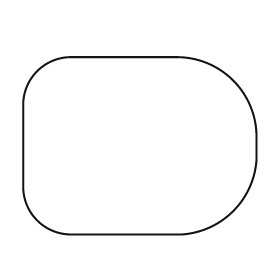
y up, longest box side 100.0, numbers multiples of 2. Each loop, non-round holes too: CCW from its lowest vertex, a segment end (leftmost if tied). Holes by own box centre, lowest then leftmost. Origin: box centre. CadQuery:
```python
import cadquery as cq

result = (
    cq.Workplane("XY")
    .moveTo(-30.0, -38.0)
    .lineTo(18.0, -38.0)
    .threePointArc((40.0, -28.0), (50.0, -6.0))
    .lineTo(50.0, 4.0)
    .threePointArc((40.0, 28.0), (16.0, 38.0))
    .lineTo(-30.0, 38.0)
    .threePointArc((-44.0, 32.0), (-50.0, 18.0))
    .lineTo(-50.0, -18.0)
    .threePointArc((-44.0, -32.0), (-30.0, -38.0))
    .close()
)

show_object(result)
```